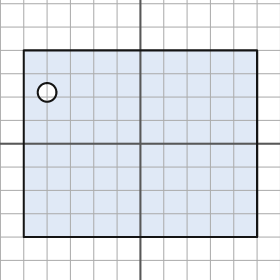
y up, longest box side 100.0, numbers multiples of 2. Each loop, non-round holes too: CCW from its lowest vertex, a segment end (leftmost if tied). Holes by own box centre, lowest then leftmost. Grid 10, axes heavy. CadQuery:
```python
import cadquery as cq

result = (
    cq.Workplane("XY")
    .moveTo(-50.0, -40.0)
    .lineTo(50.0, -40.0)
    .lineTo(50.0, 40.0)
    .lineTo(-50.0, 40.0)
    .close()
    .moveTo(-40.0, 22.0)
    .circle(4.0)
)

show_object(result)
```